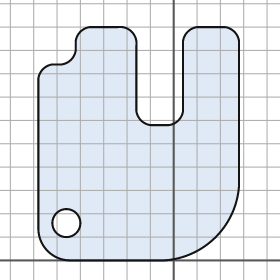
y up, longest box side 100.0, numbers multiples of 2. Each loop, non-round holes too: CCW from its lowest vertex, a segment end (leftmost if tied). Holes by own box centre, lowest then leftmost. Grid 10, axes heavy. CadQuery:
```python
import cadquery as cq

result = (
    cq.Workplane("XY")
    .moveTo(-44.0, 0.0)
    .lineTo(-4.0, 0.0)
    .threePointArc((18.0, 10.0), (28.0, 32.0))
    .lineTo(28.0, 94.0)
    .threePointArc((26.0, 98.0), (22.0, 100.0))
    .lineTo(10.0, 100.0)
    .threePointArc((6.0, 98.0), (4.0, 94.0))
    .lineTo(4.0, 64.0)
    .threePointArc((2.0, 60.0), (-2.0, 58.0))
    .lineTo(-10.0, 58.0)
    .threePointArc((-14.0, 60.0), (-16.0, 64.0))
    .lineTo(-16.0, 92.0)
    .threePointArc((-18.0, 98.0), (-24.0, 100.0))
    .lineTo(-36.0, 100.0)
    .threePointArc((-40.0, 98.0), (-42.0, 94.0))
    .lineTo(-42.0, 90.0)
    .threePointArc((-44.0, 86.0), (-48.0, 84.0))
    .lineTo(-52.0, 84.0)
    .threePointArc((-56.0, 82.0), (-58.0, 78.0))
    .lineTo(-58.0, 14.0)
    .threePointArc((-54.0, 4.0), (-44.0, 0.0))
    .close()
    .moveTo(-46.0, 16.0)
    .circle(6.0)
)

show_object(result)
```